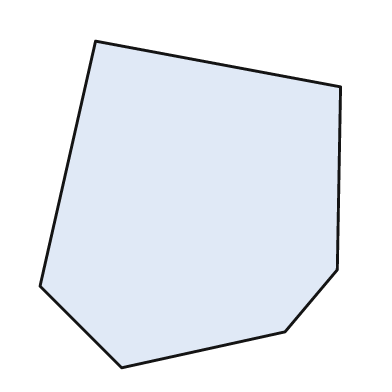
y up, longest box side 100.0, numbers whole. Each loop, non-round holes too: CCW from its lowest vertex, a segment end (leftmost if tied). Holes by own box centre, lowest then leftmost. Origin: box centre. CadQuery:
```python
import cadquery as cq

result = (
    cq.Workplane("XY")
    .moveTo(-21.0, -50.0)
    .lineTo(29.0, -39.0)
    .lineTo(45.0, -20.0)
    .lineTo(46.0, 36.0)
    .lineTo(-29.0, 50.0)
    .lineTo(-46.0, -25.0)
    .close()
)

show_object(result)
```